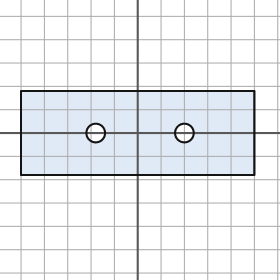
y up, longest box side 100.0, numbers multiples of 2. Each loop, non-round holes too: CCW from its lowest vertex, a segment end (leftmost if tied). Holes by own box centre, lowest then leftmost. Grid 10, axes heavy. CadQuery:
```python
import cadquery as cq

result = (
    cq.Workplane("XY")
    .moveTo(-50.0, -18.0)
    .lineTo(50.0, -18.0)
    .lineTo(50.0, 18.0)
    .lineTo(-50.0, 18.0)
    .close()
    .moveTo(-18.0, 0.0)
    .circle(4.0)
    .moveTo(20.0, 0.0)
    .circle(4.0)
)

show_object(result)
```